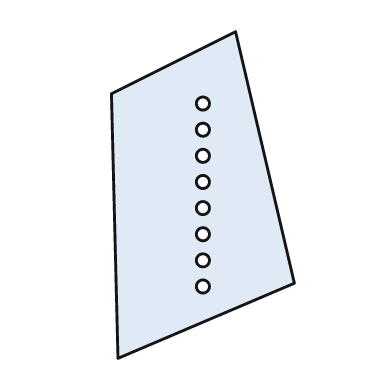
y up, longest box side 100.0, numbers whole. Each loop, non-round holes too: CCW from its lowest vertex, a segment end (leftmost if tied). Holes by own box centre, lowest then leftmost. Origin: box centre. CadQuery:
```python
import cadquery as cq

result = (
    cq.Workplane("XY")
    .moveTo(-26.0, -50.0)
    .lineTo(28.0, -27.0)
    .lineTo(10.0, 50.0)
    .lineTo(-28.0, 31.0)
    .close()
    .moveTo(0.0, -28.0)
    .circle(2.0)
    .moveTo(0.0, -20.0)
    .circle(2.0)
    .moveTo(0.0, -12.0)
    .circle(2.0)
    .moveTo(0.0, -4.0)
    .circle(2.0)
    .moveTo(0.0, 4.0)
    .circle(2.0)
    .moveTo(0.0, 12.0)
    .circle(2.0)
    .moveTo(0.0, 20.0)
    .circle(2.0)
    .moveTo(0.0, 28.0)
    .circle(2.0)
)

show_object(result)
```